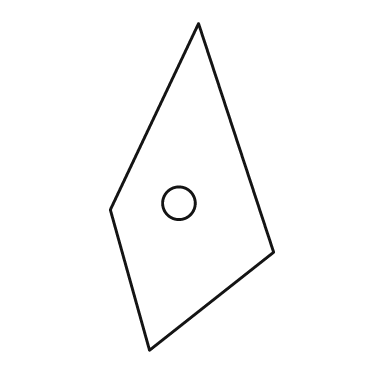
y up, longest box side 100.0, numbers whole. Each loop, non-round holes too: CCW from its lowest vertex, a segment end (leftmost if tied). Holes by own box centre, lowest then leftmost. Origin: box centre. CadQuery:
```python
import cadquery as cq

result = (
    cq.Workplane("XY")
    .moveTo(-13.0, -50.0)
    .lineTo(25.0, -20.0)
    .lineTo(2.0, 50.0)
    .lineTo(-25.0, -7.0)
    .close()
    .moveTo(-4.0, -5.0)
    .circle(5.0)
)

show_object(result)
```